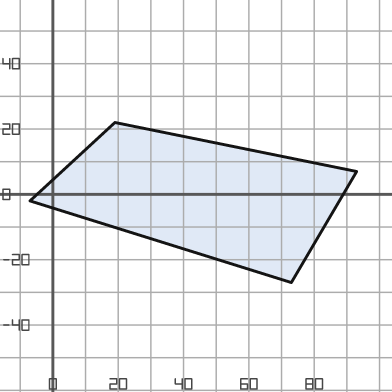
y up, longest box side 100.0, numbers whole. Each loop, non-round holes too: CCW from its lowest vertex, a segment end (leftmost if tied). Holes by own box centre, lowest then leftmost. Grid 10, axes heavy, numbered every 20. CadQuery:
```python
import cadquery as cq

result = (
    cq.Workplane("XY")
    .moveTo(73.0, -27.0)
    .lineTo(93.0, 7.0)
    .lineTo(19.0, 22.0)
    .lineTo(-7.0, -2.0)
    .close()
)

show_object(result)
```